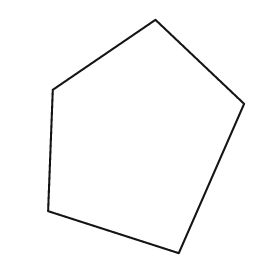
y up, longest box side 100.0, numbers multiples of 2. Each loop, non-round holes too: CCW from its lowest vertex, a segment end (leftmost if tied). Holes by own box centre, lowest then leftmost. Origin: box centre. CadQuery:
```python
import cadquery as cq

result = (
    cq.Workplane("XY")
    .moveTo(14.0, -50.0)
    .lineTo(42.0, 14.0)
    .lineTo(4.0, 50.0)
    .lineTo(-40.0, 20.0)
    .lineTo(-42.0, -32.0)
    .close()
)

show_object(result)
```